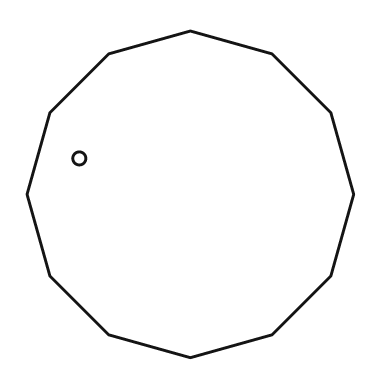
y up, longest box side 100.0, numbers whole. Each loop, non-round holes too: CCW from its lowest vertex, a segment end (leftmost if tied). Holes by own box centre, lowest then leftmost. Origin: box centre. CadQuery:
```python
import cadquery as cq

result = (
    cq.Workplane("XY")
    .moveTo(0.0, -50.0)
    .lineTo(25.0, -43.0)
    .lineTo(43.0, -25.0)
    .lineTo(50.0, 0.0)
    .lineTo(43.0, 25.0)
    .lineTo(25.0, 43.0)
    .lineTo(0.0, 50.0)
    .lineTo(-25.0, 43.0)
    .lineTo(-43.0, 25.0)
    .lineTo(-50.0, 0.0)
    .lineTo(-43.0, -25.0)
    .lineTo(-25.0, -43.0)
    .close()
    .moveTo(-34.0, 11.0)
    .circle(2.0)
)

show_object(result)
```